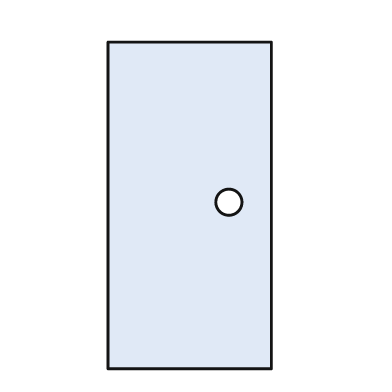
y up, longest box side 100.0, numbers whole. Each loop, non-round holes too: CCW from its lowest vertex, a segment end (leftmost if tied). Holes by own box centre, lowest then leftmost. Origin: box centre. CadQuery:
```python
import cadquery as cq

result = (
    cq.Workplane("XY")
    .moveTo(-25.0, -50.0)
    .lineTo(25.0, -50.0)
    .lineTo(25.0, 50.0)
    .lineTo(-25.0, 50.0)
    .close()
    .moveTo(12.0, 1.0)
    .circle(4.0)
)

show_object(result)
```